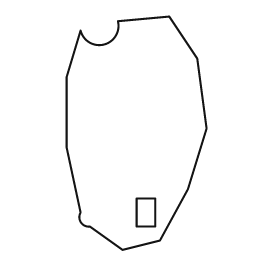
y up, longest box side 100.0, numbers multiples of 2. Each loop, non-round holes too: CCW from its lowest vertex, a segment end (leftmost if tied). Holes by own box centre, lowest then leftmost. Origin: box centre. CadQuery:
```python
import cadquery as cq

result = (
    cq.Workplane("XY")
    .moveTo(-6.0, -50.0)
    .lineTo(10.0, -46.0)
    .lineTo(22.0, -24.0)
    .lineTo(30.0, 2.0)
    .lineTo(26.0, 32.0)
    .lineTo(14.0, 50.0)
    .lineTo(-8.0, 48.0)
    .threePointArc((-14.0, 38.0), (-24.0, 44.0))
    .lineTo(-30.0, 24.0)
    .lineTo(-30.0, -6.0)
    .lineTo(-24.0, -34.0)
    .threePointArc((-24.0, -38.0), (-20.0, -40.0))
    .close()
    .moveTo(0.0, -40.0)
    .lineTo(8.0, -40.0)
    .lineTo(8.0, -28.0)
    .lineTo(0.0, -28.0)
    .close()
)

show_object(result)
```